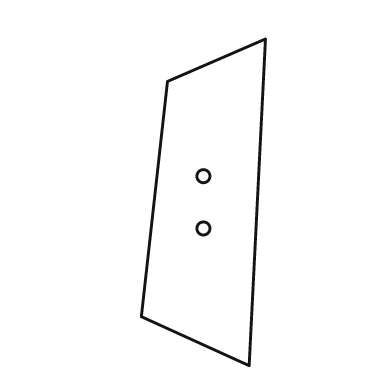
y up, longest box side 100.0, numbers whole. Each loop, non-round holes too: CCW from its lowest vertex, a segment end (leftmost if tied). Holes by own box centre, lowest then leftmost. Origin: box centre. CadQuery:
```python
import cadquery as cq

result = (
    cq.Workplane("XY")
    .moveTo(14.0, -50.0)
    .lineTo(19.0, 50.0)
    .lineTo(-11.0, 37.0)
    .lineTo(-19.0, -35.0)
    .close()
    .moveTo(0.0, -8.0)
    .circle(2.0)
    .moveTo(0.0, 8.0)
    .circle(2.0)
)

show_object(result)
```